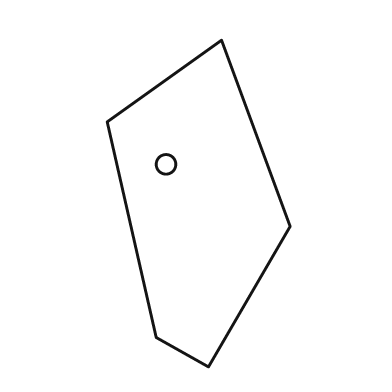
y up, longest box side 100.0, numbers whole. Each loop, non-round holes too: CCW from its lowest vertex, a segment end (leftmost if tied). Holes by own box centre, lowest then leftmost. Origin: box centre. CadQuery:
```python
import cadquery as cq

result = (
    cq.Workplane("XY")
    .moveTo(3.0, -50.0)
    .lineTo(28.0, -7.0)
    .lineTo(7.0, 50.0)
    .lineTo(-28.0, 25.0)
    .lineTo(-13.0, -41.0)
    .close()
    .moveTo(-10.0, 12.0)
    .circle(3.0)
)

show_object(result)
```